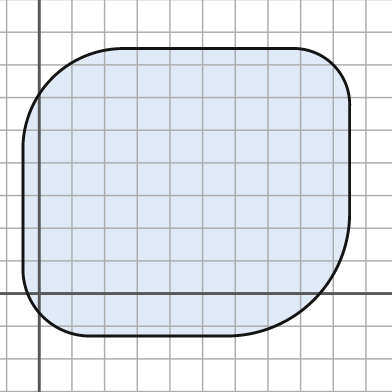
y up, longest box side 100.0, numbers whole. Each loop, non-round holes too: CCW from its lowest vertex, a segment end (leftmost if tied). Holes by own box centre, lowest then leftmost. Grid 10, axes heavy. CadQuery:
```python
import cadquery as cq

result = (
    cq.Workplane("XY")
    .moveTo(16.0, -13.0)
    .lineTo(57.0, -13.0)
    .threePointArc((84.0, -2.0), (95.0, 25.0))
    .lineTo(95.0, 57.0)
    .threePointArc((90.0, 70.0), (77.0, 75.0))
    .lineTo(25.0, 75.0)
    .threePointArc((4.0, 66.0), (-5.0, 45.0))
    .lineTo(-5.0, 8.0)
    .threePointArc((1.0, -7.0), (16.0, -13.0))
    .close()
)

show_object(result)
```